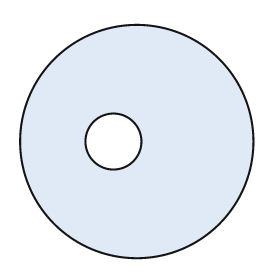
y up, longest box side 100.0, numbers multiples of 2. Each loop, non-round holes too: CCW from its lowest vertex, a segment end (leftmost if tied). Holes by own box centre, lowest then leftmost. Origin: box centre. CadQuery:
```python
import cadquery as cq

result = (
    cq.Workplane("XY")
    .moveTo(0.0, 0.0)
    .circle(50.0)
    .moveTo(-10.0, 0.0)
    .circle(12.0)
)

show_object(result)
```